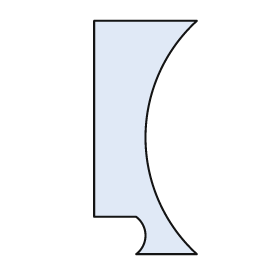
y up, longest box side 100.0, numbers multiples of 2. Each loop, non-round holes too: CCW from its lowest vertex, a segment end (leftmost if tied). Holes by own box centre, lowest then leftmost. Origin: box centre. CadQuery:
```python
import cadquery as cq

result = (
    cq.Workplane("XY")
    .moveTo(-4.0, -50.0)
    .lineTo(22.0, -50.0)
    .threePointArc((0.0, 0.0), (22.0, 50.0))
    .lineTo(-22.0, 50.0)
    .lineTo(-22.0, -34.0)
    .lineTo(-4.0, -34.0)
    .threePointArc((0.0, -42.0), (-4.0, -50.0))
    .close()
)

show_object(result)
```